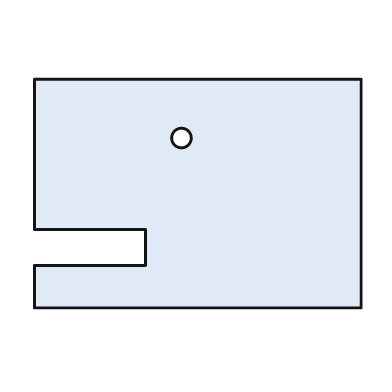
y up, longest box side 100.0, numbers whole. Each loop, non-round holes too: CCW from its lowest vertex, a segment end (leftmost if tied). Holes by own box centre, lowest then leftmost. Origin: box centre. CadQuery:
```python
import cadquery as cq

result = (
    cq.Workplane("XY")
    .moveTo(-50.0, -35.0)
    .lineTo(50.0, -35.0)
    .lineTo(50.0, 35.0)
    .lineTo(-50.0, 35.0)
    .lineTo(-50.0, -11.0)
    .lineTo(-16.0, -11.0)
    .lineTo(-16.0, -22.0)
    .lineTo(-50.0, -22.0)
    .close()
    .moveTo(-5.0, 17.0)
    .circle(3.0)
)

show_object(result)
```